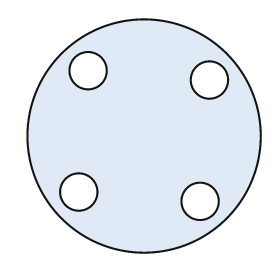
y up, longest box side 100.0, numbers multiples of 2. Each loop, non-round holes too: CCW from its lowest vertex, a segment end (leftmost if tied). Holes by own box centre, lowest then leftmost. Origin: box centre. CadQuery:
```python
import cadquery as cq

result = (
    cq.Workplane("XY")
    .moveTo(0.0, 0.0)
    .circle(50.0)
    .moveTo(24.0, -28.0)
    .circle(8.0)
    .moveTo(-28.0, -24.0)
    .circle(8.0)
    .moveTo(28.0, 24.0)
    .circle(8.0)
    .moveTo(-24.0, 28.0)
    .circle(8.0)
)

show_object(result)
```